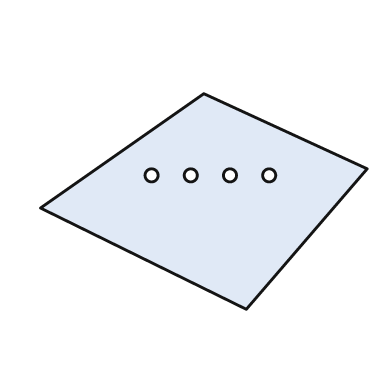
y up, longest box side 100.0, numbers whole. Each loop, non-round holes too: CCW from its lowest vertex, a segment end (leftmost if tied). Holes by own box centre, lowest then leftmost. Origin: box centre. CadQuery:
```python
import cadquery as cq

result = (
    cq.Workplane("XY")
    .moveTo(13.0, -33.0)
    .lineTo(50.0, 10.0)
    .lineTo(0.0, 33.0)
    .lineTo(-50.0, -2.0)
    .close()
    .moveTo(-16.0, 8.0)
    .circle(2.0)
    .moveTo(-4.0, 8.0)
    .circle(2.0)
    .moveTo(8.0, 8.0)
    .circle(2.0)
    .moveTo(20.0, 8.0)
    .circle(2.0)
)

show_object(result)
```